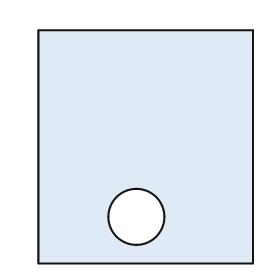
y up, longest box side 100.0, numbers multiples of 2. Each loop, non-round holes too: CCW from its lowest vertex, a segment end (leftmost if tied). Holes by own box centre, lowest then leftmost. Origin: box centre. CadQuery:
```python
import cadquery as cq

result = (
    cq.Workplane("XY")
    .moveTo(-46.0, -50.0)
    .lineTo(46.0, -50.0)
    .lineTo(46.0, 50.0)
    .lineTo(-46.0, 50.0)
    .close()
    .moveTo(-4.0, -30.0)
    .circle(12.0)
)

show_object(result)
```